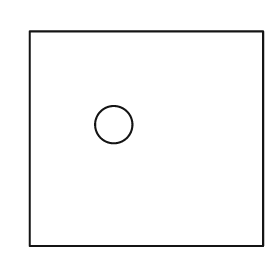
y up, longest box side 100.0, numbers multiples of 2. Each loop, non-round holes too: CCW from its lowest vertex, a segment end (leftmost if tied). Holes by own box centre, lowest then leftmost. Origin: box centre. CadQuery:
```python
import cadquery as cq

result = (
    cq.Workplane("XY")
    .moveTo(-50.0, -46.0)
    .lineTo(50.0, -46.0)
    .lineTo(50.0, 46.0)
    .lineTo(-50.0, 46.0)
    .close()
    .moveTo(-14.0, 6.0)
    .circle(8.0)
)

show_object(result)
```